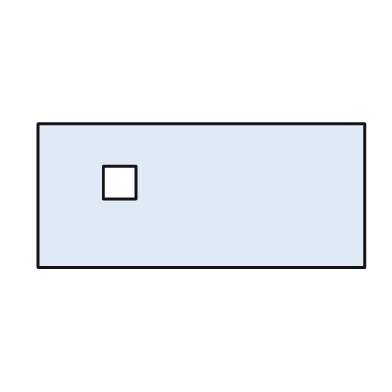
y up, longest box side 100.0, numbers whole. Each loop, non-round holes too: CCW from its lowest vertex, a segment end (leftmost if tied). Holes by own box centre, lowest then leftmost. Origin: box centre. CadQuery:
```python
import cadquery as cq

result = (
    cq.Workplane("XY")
    .moveTo(-50.0, -22.0)
    .lineTo(50.0, -22.0)
    .lineTo(50.0, 22.0)
    .lineTo(-50.0, 22.0)
    .close()
    .moveTo(-30.0, -1.0)
    .lineTo(-20.0, -1.0)
    .lineTo(-20.0, 9.0)
    .lineTo(-30.0, 9.0)
    .close()
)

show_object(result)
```